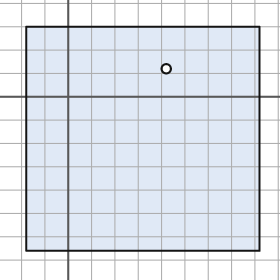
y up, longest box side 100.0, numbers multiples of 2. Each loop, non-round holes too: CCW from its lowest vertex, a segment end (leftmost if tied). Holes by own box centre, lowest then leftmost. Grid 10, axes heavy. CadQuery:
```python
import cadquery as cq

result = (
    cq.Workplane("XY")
    .moveTo(-18.0, -66.0)
    .lineTo(82.0, -66.0)
    .lineTo(82.0, 30.0)
    .lineTo(-18.0, 30.0)
    .close()
    .moveTo(42.0, 12.0)
    .circle(2.0)
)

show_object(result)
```